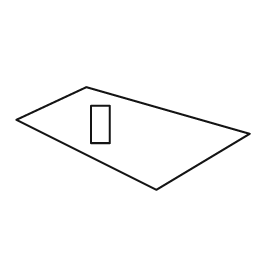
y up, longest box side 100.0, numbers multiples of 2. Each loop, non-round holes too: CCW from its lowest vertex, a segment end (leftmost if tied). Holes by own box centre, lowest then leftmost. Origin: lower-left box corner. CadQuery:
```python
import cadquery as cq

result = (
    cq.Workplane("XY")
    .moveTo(60.0, 0.0)
    .lineTo(100.0, 24.0)
    .lineTo(30.0, 44.0)
    .lineTo(0.0, 30.0)
    .close()
    .moveTo(32.0, 20.0)
    .lineTo(40.0, 20.0)
    .lineTo(40.0, 36.0)
    .lineTo(32.0, 36.0)
    .close()
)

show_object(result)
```